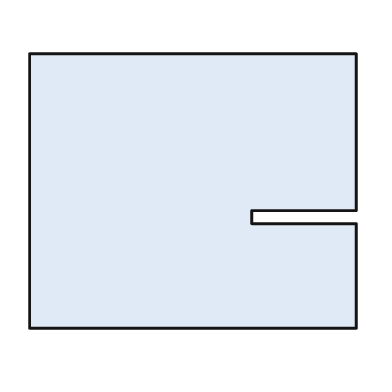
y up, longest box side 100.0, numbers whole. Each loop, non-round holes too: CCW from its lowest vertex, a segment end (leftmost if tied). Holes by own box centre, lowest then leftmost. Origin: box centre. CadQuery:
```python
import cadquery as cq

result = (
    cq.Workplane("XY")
    .moveTo(-50.0, -42.0)
    .lineTo(50.0, -42.0)
    .lineTo(50.0, -10.0)
    .lineTo(18.0, -10.0)
    .lineTo(18.0, -6.0)
    .lineTo(50.0, -6.0)
    .lineTo(50.0, 42.0)
    .lineTo(-50.0, 42.0)
    .close()
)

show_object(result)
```